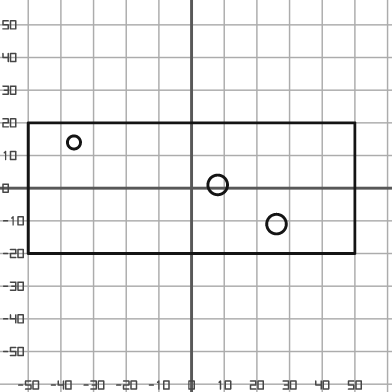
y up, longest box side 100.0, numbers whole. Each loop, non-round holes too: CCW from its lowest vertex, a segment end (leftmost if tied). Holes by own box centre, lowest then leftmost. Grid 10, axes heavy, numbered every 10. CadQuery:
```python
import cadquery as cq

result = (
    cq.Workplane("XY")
    .moveTo(-50.0, -20.0)
    .lineTo(50.0, -20.0)
    .lineTo(50.0, 20.0)
    .lineTo(-50.0, 20.0)
    .close()
    .moveTo(26.0, -11.0)
    .circle(3.0)
    .moveTo(8.0, 1.0)
    .circle(3.0)
    .moveTo(-36.0, 14.0)
    .circle(2.0)
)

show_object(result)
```